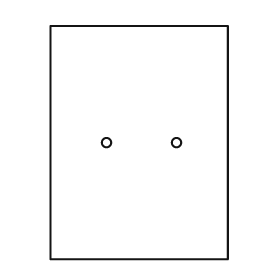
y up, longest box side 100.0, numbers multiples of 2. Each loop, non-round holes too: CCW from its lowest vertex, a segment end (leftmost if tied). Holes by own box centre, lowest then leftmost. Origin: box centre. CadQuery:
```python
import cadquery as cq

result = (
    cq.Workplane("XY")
    .moveTo(-38.0, -50.0)
    .lineTo(38.0, -50.0)
    .lineTo(38.0, 50.0)
    .lineTo(-38.0, 50.0)
    .close()
    .moveTo(-14.0, 0.0)
    .circle(2.0)
    .moveTo(16.0, 0.0)
    .circle(2.0)
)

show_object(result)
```